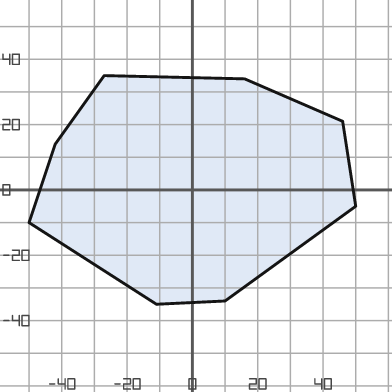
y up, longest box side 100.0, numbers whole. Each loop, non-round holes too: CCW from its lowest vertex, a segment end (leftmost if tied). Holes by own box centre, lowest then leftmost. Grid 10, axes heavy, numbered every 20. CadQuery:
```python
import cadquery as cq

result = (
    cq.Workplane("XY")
    .moveTo(-11.0, -35.0)
    .lineTo(10.0, -34.0)
    .lineTo(50.0, -5.0)
    .lineTo(46.0, 21.0)
    .lineTo(16.0, 34.0)
    .lineTo(-27.0, 35.0)
    .lineTo(-42.0, 14.0)
    .lineTo(-50.0, -10.0)
    .close()
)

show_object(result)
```